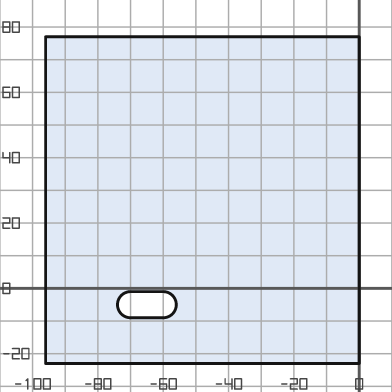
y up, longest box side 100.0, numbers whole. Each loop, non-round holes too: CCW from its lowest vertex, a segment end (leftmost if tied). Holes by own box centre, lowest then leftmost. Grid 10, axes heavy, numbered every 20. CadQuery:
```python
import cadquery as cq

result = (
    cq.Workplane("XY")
    .moveTo(-96.0, -23.0)
    .lineTo(0.0, -23.0)
    .lineTo(0.0, 77.0)
    .lineTo(-96.0, 77.0)
    .close()
    .moveTo(-70.0, -9.0)
    .lineTo(-60.0, -9.0)
    .threePointArc((-56.0, -5.0), (-60.0, -1.0))
    .lineTo(-70.0, -1.0)
    .threePointArc((-74.0, -5.0), (-70.0, -9.0))
    .close()
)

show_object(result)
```